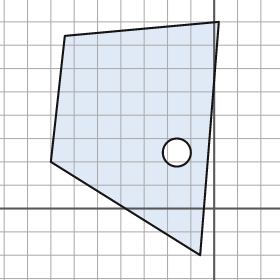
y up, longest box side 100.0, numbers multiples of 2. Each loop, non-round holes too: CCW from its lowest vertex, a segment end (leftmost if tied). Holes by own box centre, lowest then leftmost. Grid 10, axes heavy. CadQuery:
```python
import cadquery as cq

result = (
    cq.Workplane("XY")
    .moveTo(-6.0, -20.0)
    .lineTo(2.0, 80.0)
    .lineTo(-64.0, 74.0)
    .lineTo(-70.0, 20.0)
    .close()
    .moveTo(-16.0, 24.0)
    .circle(6.0)
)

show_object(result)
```